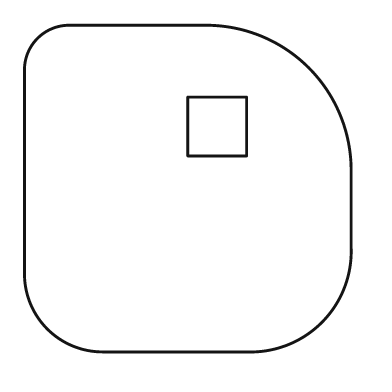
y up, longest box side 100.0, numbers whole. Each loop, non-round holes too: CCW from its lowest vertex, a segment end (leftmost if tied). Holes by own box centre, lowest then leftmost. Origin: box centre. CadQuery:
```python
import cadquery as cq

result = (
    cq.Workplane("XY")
    .moveTo(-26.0, -50.0)
    .lineTo(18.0, -50.0)
    .threePointArc((41.0, -41.0), (50.0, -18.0))
    .lineTo(50.0, 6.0)
    .threePointArc((37.0, 37.0), (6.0, 50.0))
    .lineTo(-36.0, 50.0)
    .threePointArc((-46.0, 46.0), (-50.0, 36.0))
    .lineTo(-50.0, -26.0)
    .threePointArc((-43.0, -43.0), (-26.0, -50.0))
    .close()
    .moveTo(0.0, 10.0)
    .lineTo(18.0, 10.0)
    .lineTo(18.0, 28.0)
    .lineTo(0.0, 28.0)
    .close()
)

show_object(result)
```